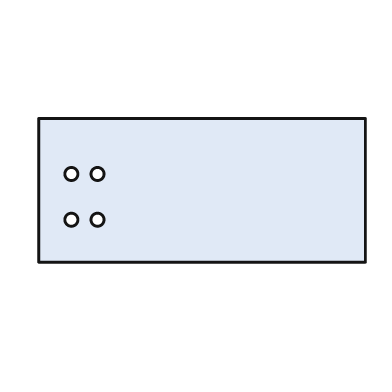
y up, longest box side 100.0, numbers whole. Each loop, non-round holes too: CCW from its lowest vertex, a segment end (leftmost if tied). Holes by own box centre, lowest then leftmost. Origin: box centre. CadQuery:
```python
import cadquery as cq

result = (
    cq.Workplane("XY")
    .moveTo(-50.0, -22.0)
    .lineTo(50.0, -22.0)
    .lineTo(50.0, 22.0)
    .lineTo(-50.0, 22.0)
    .close()
    .moveTo(-40.0, -9.0)
    .circle(2.0)
    .moveTo(-32.0, -9.0)
    .circle(2.0)
    .moveTo(-40.0, 5.0)
    .circle(2.0)
    .moveTo(-32.0, 5.0)
    .circle(2.0)
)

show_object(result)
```